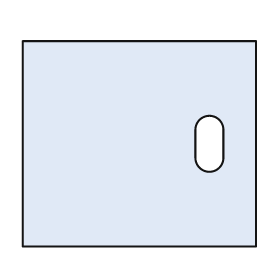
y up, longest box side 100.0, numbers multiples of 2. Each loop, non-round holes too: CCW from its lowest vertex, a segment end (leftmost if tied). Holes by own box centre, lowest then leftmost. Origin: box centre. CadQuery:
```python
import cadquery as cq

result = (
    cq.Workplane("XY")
    .moveTo(-50.0, -44.0)
    .lineTo(50.0, -44.0)
    .lineTo(50.0, 44.0)
    .lineTo(-50.0, 44.0)
    .close()
    .moveTo(24.0, -6.0)
    .threePointArc((30.0, -12.0), (36.0, -6.0))
    .lineTo(36.0, 6.0)
    .threePointArc((30.0, 12.0), (24.0, 6.0))
    .close()
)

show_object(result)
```